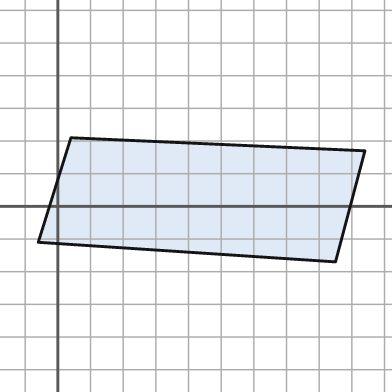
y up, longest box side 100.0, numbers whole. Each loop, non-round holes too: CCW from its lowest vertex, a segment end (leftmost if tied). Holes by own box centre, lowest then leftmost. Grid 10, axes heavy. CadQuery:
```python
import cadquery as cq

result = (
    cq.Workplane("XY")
    .moveTo(85.0, -17.0)
    .lineTo(94.0, 17.0)
    .lineTo(4.0, 21.0)
    .lineTo(-6.0, -11.0)
    .close()
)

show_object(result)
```